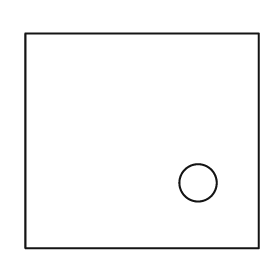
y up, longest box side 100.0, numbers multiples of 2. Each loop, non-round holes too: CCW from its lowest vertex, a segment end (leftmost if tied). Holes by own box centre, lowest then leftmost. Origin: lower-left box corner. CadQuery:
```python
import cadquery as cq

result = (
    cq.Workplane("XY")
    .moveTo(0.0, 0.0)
    .lineTo(100.0, 0.0)
    .lineTo(100.0, 92.0)
    .lineTo(0.0, 92.0)
    .close()
    .moveTo(74.0, 28.0)
    .circle(8.0)
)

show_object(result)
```